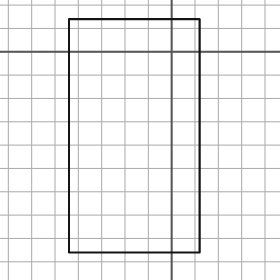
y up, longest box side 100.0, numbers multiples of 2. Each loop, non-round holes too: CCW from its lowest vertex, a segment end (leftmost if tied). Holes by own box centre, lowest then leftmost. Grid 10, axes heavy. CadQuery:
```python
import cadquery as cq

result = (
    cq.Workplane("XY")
    .moveTo(-44.0, -86.0)
    .lineTo(12.0, -86.0)
    .lineTo(12.0, 14.0)
    .lineTo(-44.0, 14.0)
    .close()
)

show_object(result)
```